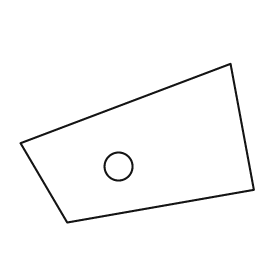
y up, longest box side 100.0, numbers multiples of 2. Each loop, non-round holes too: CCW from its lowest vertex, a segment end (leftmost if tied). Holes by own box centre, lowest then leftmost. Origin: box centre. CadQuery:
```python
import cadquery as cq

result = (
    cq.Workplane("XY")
    .moveTo(-30.0, -34.0)
    .lineTo(50.0, -20.0)
    .lineTo(40.0, 34.0)
    .lineTo(-50.0, 0.0)
    .close()
    .moveTo(-8.0, -10.0)
    .circle(6.0)
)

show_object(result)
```